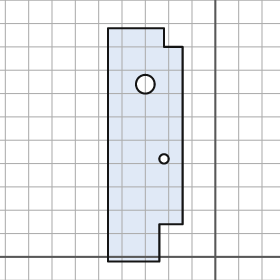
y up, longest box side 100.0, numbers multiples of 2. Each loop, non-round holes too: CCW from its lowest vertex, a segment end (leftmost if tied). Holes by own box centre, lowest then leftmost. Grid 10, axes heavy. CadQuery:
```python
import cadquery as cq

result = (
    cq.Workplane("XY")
    .moveTo(-46.0, -2.0)
    .lineTo(-24.0, -2.0)
    .lineTo(-24.0, 14.0)
    .lineTo(-14.0, 14.0)
    .lineTo(-14.0, 90.0)
    .lineTo(-22.0, 90.0)
    .lineTo(-22.0, 98.0)
    .lineTo(-46.0, 98.0)
    .close()
    .moveTo(-22.0, 42.0)
    .circle(2.0)
    .moveTo(-30.0, 74.0)
    .circle(4.0)
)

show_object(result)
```